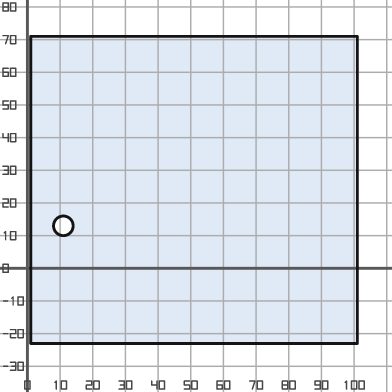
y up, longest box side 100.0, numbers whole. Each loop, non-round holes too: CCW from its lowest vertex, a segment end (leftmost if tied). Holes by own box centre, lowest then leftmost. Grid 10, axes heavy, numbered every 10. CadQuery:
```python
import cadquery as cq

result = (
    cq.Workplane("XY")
    .moveTo(1.0, -23.0)
    .lineTo(101.0, -23.0)
    .lineTo(101.0, 71.0)
    .lineTo(1.0, 71.0)
    .close()
    .moveTo(11.0, 13.0)
    .circle(3.0)
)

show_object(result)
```